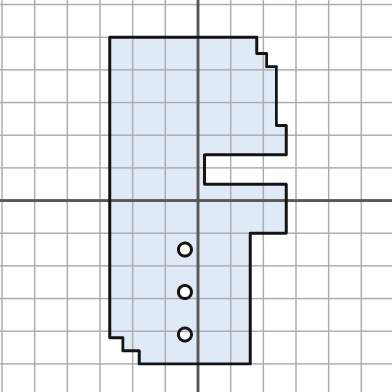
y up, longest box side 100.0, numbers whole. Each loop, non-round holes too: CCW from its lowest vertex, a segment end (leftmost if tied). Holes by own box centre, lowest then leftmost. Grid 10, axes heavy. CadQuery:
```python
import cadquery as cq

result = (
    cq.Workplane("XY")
    .moveTo(-18.0, -50.0)
    .lineTo(16.0, -50.0)
    .lineTo(16.0, -10.0)
    .lineTo(27.0, -10.0)
    .lineTo(27.0, 5.0)
    .lineTo(2.0, 5.0)
    .lineTo(2.0, 14.0)
    .lineTo(27.0, 14.0)
    .lineTo(27.0, 23.0)
    .lineTo(24.0, 23.0)
    .lineTo(24.0, 41.0)
    .lineTo(21.0, 41.0)
    .lineTo(21.0, 45.0)
    .lineTo(18.0, 45.0)
    .lineTo(18.0, 50.0)
    .lineTo(-27.0, 50.0)
    .lineTo(-27.0, -42.0)
    .lineTo(-23.0, -42.0)
    .lineTo(-23.0, -46.0)
    .lineTo(-18.0, -46.0)
    .close()
    .moveTo(-4.0, -41.0)
    .circle(2.0)
    .moveTo(-4.0, -28.0)
    .circle(2.0)
    .moveTo(-4.0, -15.0)
    .circle(2.0)
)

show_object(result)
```